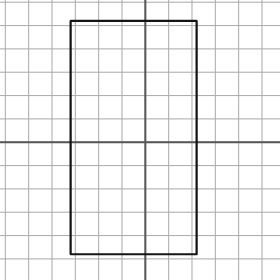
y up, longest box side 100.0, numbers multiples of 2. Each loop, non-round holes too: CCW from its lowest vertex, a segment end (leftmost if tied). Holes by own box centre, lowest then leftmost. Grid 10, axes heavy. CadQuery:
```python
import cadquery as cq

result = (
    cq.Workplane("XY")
    .moveTo(-32.0, -48.0)
    .lineTo(22.0, -48.0)
    .lineTo(22.0, 52.0)
    .lineTo(-32.0, 52.0)
    .close()
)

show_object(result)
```